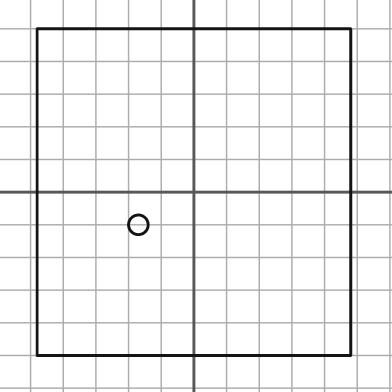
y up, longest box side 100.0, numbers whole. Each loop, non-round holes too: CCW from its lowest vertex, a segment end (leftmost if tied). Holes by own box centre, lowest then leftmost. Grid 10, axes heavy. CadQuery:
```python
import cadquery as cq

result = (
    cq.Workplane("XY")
    .moveTo(-48.0, -50.0)
    .lineTo(48.0, -50.0)
    .lineTo(48.0, 50.0)
    .lineTo(-48.0, 50.0)
    .close()
    .moveTo(-17.0, -10.0)
    .circle(3.0)
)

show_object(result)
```